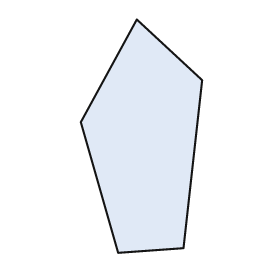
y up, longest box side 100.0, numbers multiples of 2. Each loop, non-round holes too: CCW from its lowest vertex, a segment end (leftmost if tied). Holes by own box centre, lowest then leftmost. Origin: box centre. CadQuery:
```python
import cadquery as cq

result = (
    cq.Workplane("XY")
    .moveTo(-10.0, -50.0)
    .lineTo(18.0, -48.0)
    .lineTo(26.0, 24.0)
    .lineTo(-2.0, 50.0)
    .lineTo(-26.0, 6.0)
    .close()
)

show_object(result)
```